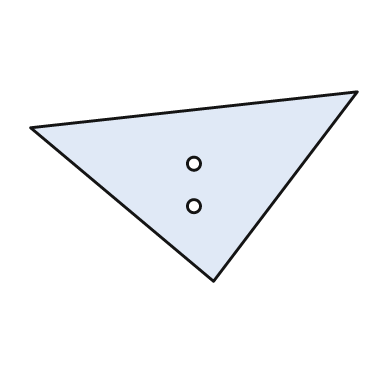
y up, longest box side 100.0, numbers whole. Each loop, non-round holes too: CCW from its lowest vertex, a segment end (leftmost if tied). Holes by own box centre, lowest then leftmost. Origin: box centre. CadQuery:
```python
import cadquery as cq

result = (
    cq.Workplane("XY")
    .moveTo(6.0, -29.0)
    .lineTo(50.0, 29.0)
    .lineTo(-50.0, 18.0)
    .close()
    .moveTo(0.0, -6.0)
    .circle(2.0)
    .moveTo(0.0, 7.0)
    .circle(2.0)
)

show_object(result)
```